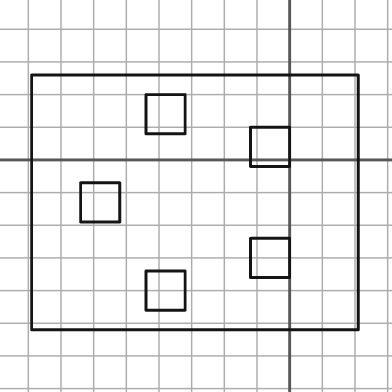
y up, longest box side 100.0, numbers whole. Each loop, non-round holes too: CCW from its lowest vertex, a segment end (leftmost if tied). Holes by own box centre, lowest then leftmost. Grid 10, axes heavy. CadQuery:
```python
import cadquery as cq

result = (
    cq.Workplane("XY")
    .moveTo(-79.0, -52.0)
    .lineTo(21.0, -52.0)
    .lineTo(21.0, 26.0)
    .lineTo(-79.0, 26.0)
    .close()
    .moveTo(-44.0, -46.0)
    .lineTo(-32.0, -46.0)
    .lineTo(-32.0, -34.0)
    .lineTo(-44.0, -34.0)
    .close()
    .moveTo(-12.0, -36.0)
    .lineTo(0.0, -36.0)
    .lineTo(0.0, -24.0)
    .lineTo(-12.0, -24.0)
    .close()
    .moveTo(-64.0, -19.0)
    .lineTo(-52.0, -19.0)
    .lineTo(-52.0, -7.0)
    .lineTo(-64.0, -7.0)
    .close()
    .moveTo(-12.0, -2.0)
    .lineTo(0.0, -2.0)
    .lineTo(0.0, 10.0)
    .lineTo(-12.0, 10.0)
    .close()
    .moveTo(-44.0, 8.0)
    .lineTo(-32.0, 8.0)
    .lineTo(-32.0, 20.0)
    .lineTo(-44.0, 20.0)
    .close()
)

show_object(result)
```